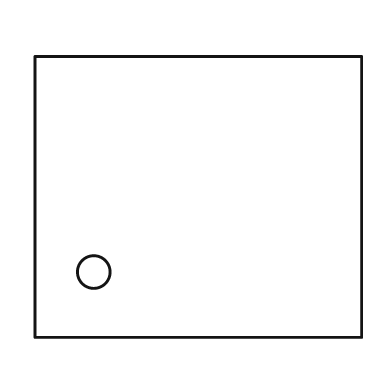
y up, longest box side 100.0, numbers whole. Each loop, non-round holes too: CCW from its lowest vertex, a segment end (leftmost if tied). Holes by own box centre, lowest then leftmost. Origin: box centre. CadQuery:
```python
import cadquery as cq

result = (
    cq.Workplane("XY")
    .moveTo(-50.0, -43.0)
    .lineTo(50.0, -43.0)
    .lineTo(50.0, 43.0)
    .lineTo(-50.0, 43.0)
    .close()
    .moveTo(-32.0, -23.0)
    .circle(5.0)
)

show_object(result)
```